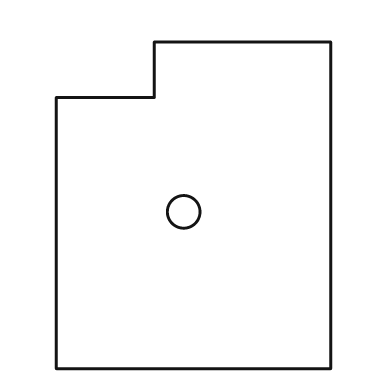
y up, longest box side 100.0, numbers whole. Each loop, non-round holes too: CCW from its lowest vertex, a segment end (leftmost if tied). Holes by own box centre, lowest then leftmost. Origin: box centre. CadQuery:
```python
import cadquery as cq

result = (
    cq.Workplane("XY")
    .moveTo(-42.0, -50.0)
    .lineTo(42.0, -50.0)
    .lineTo(42.0, 50.0)
    .lineTo(-12.0, 50.0)
    .lineTo(-12.0, 33.0)
    .lineTo(-42.0, 33.0)
    .close()
    .moveTo(-3.0, -2.0)
    .circle(5.0)
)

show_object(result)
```